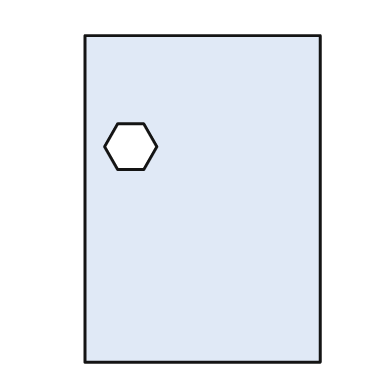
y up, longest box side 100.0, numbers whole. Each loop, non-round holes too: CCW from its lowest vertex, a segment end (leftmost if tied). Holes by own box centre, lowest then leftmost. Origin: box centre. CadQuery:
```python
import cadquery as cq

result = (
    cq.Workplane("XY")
    .moveTo(-36.0, -50.0)
    .lineTo(36.0, -50.0)
    .lineTo(36.0, 50.0)
    .lineTo(-36.0, 50.0)
    .close()
    .moveTo(-26.0, 9.0)
    .lineTo(-18.0, 9.0)
    .lineTo(-14.0, 16.0)
    .lineTo(-18.0, 23.0)
    .lineTo(-26.0, 23.0)
    .lineTo(-30.0, 16.0)
    .close()
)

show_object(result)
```